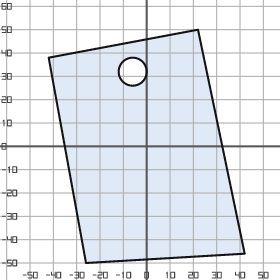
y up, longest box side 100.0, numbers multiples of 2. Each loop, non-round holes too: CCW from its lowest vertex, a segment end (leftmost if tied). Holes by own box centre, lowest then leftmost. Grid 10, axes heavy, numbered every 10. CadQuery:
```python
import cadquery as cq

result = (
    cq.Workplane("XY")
    .moveTo(-26.0, -50.0)
    .lineTo(42.0, -46.0)
    .lineTo(22.0, 50.0)
    .lineTo(-42.0, 38.0)
    .close()
    .moveTo(-6.0, 32.0)
    .circle(6.0)
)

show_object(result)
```